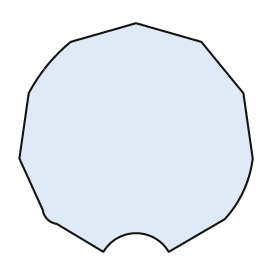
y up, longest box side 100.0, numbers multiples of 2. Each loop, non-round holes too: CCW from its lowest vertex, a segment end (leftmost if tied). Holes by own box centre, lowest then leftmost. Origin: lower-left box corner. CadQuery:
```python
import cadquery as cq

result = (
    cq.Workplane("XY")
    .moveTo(36.0, 0.0)
    .threePointArc((50.0, 8.0), (64.0, 0.0))
    .lineTo(88.0, 14.0)
    .threePointArc((96.0, 26.0), (100.0, 40.0))
    .lineTo(96.0, 68.0)
    .lineTo(78.0, 90.0)
    .lineTo(50.0, 98.0)
    .lineTo(22.0, 90.0)
    .threePointArc((12.0, 80.0), (4.0, 68.0))
    .lineTo(0.0, 40.0)
    .lineTo(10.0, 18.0)
    .threePointArc((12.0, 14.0), (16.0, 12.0))
    .close()
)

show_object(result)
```